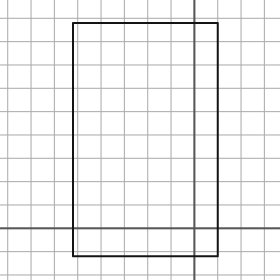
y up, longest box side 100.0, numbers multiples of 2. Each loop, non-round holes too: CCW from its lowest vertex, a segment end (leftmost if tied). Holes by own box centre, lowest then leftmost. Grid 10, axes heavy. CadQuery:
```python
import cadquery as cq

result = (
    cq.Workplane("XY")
    .moveTo(-52.0, -12.0)
    .lineTo(10.0, -12.0)
    .lineTo(10.0, 88.0)
    .lineTo(-52.0, 88.0)
    .close()
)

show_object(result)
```